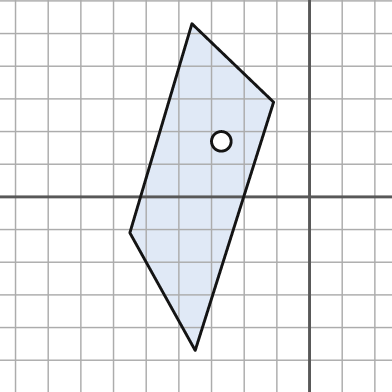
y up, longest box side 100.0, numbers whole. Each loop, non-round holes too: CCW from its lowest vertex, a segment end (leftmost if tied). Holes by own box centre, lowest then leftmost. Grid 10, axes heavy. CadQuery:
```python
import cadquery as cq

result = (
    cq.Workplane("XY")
    .moveTo(-35.0, -47.0)
    .lineTo(-11.0, 29.0)
    .lineTo(-36.0, 53.0)
    .lineTo(-55.0, -11.0)
    .close()
    .moveTo(-27.0, 17.0)
    .circle(3.0)
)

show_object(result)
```